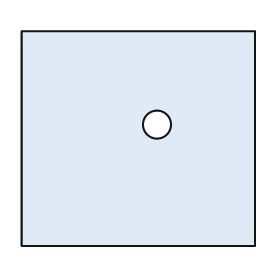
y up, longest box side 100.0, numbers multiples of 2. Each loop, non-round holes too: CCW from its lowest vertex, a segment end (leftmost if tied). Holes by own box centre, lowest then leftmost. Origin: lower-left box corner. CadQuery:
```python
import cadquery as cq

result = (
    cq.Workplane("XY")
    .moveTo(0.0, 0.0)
    .lineTo(100.0, 0.0)
    .lineTo(100.0, 92.0)
    .lineTo(0.0, 92.0)
    .close()
    .moveTo(58.0, 52.0)
    .circle(6.0)
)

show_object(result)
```